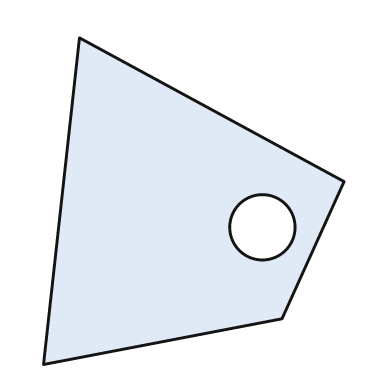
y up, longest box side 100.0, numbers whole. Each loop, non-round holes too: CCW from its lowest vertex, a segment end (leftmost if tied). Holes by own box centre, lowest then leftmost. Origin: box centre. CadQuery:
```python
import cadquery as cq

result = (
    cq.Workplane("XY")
    .moveTo(-46.0, -50.0)
    .lineTo(27.0, -36.0)
    .lineTo(46.0, 6.0)
    .lineTo(-35.0, 50.0)
    .close()
    .moveTo(21.0, -8.0)
    .circle(10.0)
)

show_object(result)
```